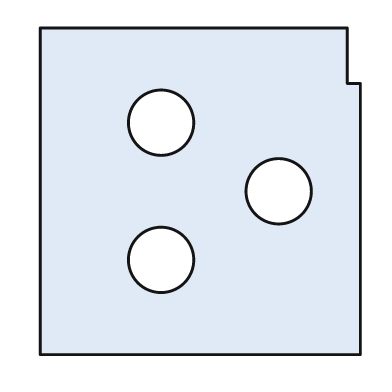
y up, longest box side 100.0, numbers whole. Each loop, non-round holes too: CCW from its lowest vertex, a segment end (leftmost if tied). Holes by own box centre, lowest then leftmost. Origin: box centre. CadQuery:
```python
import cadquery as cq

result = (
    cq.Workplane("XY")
    .moveTo(-49.0, -50.0)
    .lineTo(49.0, -50.0)
    .lineTo(49.0, 33.0)
    .lineTo(45.0, 33.0)
    .lineTo(45.0, 50.0)
    .lineTo(-49.0, 50.0)
    .close()
    .moveTo(-12.0, -21.0)
    .circle(10.0)
    .moveTo(24.0, 0.0)
    .circle(10.0)
    .moveTo(-12.0, 21.0)
    .circle(10.0)
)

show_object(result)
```